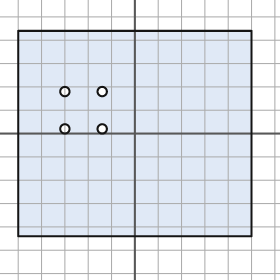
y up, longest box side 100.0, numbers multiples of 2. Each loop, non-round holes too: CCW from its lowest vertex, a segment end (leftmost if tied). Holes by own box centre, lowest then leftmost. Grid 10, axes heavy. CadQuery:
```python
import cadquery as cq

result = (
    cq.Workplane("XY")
    .moveTo(-50.0, -44.0)
    .lineTo(50.0, -44.0)
    .lineTo(50.0, 44.0)
    .lineTo(-50.0, 44.0)
    .close()
    .moveTo(-30.0, 2.0)
    .circle(2.0)
    .moveTo(-14.0, 2.0)
    .circle(2.0)
    .moveTo(-30.0, 18.0)
    .circle(2.0)
    .moveTo(-14.0, 18.0)
    .circle(2.0)
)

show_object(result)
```